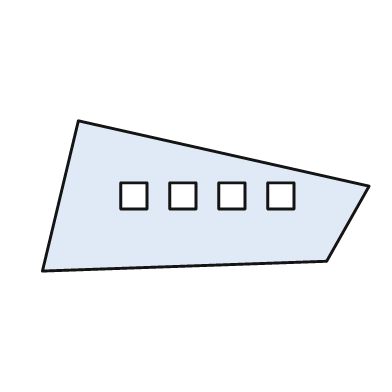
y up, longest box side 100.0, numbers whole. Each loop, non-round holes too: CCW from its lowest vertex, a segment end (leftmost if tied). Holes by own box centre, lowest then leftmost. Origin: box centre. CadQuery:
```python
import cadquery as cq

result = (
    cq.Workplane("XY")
    .moveTo(-50.0, -23.0)
    .lineTo(37.0, -20.0)
    .lineTo(50.0, 3.0)
    .lineTo(-39.0, 23.0)
    .close()
    .moveTo(-26.0, -4.0)
    .lineTo(-18.0, -4.0)
    .lineTo(-18.0, 4.0)
    .lineTo(-26.0, 4.0)
    .close()
    .moveTo(-11.0, -4.0)
    .lineTo(-3.0, -4.0)
    .lineTo(-3.0, 4.0)
    .lineTo(-11.0, 4.0)
    .close()
    .moveTo(4.0, -4.0)
    .lineTo(12.0, -4.0)
    .lineTo(12.0, 4.0)
    .lineTo(4.0, 4.0)
    .close()
    .moveTo(19.0, -4.0)
    .lineTo(27.0, -4.0)
    .lineTo(27.0, 4.0)
    .lineTo(19.0, 4.0)
    .close()
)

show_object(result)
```